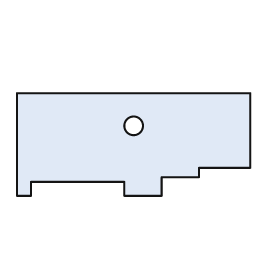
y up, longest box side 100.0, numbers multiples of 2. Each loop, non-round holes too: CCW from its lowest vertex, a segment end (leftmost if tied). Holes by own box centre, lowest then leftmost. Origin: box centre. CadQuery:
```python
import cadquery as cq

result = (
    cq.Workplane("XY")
    .moveTo(-50.0, -22.0)
    .lineTo(-44.0, -22.0)
    .lineTo(-44.0, -16.0)
    .lineTo(-4.0, -16.0)
    .lineTo(-4.0, -22.0)
    .lineTo(12.0, -22.0)
    .lineTo(12.0, -14.0)
    .lineTo(28.0, -14.0)
    .lineTo(28.0, -10.0)
    .lineTo(50.0, -10.0)
    .lineTo(50.0, 22.0)
    .lineTo(-50.0, 22.0)
    .close()
    .moveTo(0.0, 8.0)
    .circle(4.0)
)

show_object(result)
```